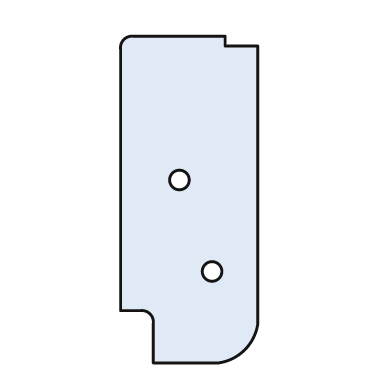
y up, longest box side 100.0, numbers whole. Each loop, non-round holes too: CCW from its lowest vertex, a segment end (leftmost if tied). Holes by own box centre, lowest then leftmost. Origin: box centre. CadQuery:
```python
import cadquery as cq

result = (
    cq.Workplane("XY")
    .moveTo(-11.0, -50.0)
    .lineTo(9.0, -50.0)
    .threePointArc((17.0, -46.0), (21.0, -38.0))
    .lineTo(21.0, 47.0)
    .lineTo(11.0, 47.0)
    .lineTo(11.0, 50.0)
    .lineTo(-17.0, 50.0)
    .threePointArc((-20.0, 49.0), (-21.0, 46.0))
    .lineTo(-21.0, -34.0)
    .lineTo(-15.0, -34.0)
    .threePointArc((-12.0, -35.0), (-11.0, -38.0))
    .close()
    .moveTo(7.0, -22.0)
    .circle(3.0)
    .moveTo(-3.0, 6.0)
    .circle(3.0)
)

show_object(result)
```